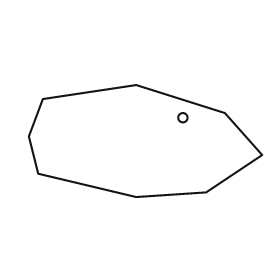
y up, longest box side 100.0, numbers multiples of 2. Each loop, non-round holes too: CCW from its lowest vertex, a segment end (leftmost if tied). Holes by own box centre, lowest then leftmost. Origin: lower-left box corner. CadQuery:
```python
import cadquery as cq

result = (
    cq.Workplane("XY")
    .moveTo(46.0, 0.0)
    .lineTo(76.0, 2.0)
    .lineTo(100.0, 18.0)
    .lineTo(84.0, 36.0)
    .lineTo(46.0, 48.0)
    .lineTo(6.0, 42.0)
    .lineTo(0.0, 26.0)
    .lineTo(4.0, 10.0)
    .close()
    .moveTo(66.0, 34.0)
    .circle(2.0)
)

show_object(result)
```